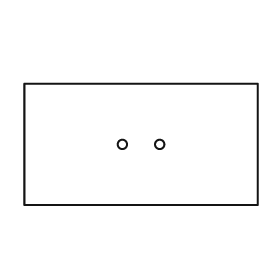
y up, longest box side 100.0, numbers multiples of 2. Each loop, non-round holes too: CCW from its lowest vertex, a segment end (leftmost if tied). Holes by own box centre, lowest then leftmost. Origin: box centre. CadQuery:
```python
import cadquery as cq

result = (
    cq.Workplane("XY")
    .moveTo(-50.0, -26.0)
    .lineTo(50.0, -26.0)
    .lineTo(50.0, 26.0)
    .lineTo(-50.0, 26.0)
    .close()
    .moveTo(-8.0, 0.0)
    .circle(2.0)
    .moveTo(8.0, 0.0)
    .circle(2.0)
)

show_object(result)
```